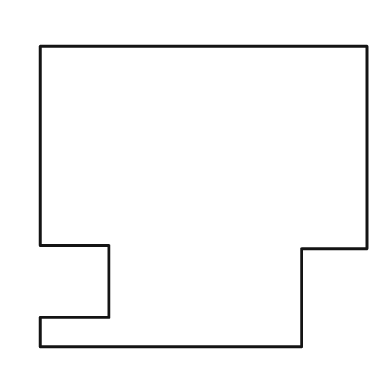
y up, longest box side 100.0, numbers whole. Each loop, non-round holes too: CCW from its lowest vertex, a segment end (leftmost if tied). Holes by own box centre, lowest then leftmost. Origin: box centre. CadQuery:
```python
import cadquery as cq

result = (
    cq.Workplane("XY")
    .moveTo(-50.0, -46.0)
    .lineTo(30.0, -46.0)
    .lineTo(30.0, -16.0)
    .lineTo(50.0, -16.0)
    .lineTo(50.0, 46.0)
    .lineTo(-50.0, 46.0)
    .lineTo(-50.0, -15.0)
    .lineTo(-29.0, -15.0)
    .lineTo(-29.0, -37.0)
    .lineTo(-50.0, -37.0)
    .close()
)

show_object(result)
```